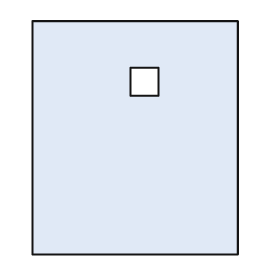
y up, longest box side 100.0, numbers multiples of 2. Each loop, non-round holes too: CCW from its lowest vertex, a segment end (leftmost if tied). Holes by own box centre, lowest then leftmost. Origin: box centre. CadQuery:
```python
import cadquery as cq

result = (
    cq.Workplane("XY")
    .moveTo(-44.0, -50.0)
    .lineTo(44.0, -50.0)
    .lineTo(44.0, 50.0)
    .lineTo(-44.0, 50.0)
    .close()
    .moveTo(-2.0, 18.0)
    .lineTo(10.0, 18.0)
    .lineTo(10.0, 30.0)
    .lineTo(-2.0, 30.0)
    .close()
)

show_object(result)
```